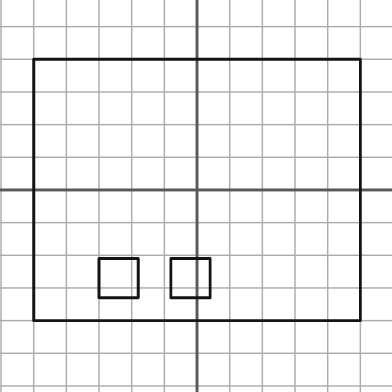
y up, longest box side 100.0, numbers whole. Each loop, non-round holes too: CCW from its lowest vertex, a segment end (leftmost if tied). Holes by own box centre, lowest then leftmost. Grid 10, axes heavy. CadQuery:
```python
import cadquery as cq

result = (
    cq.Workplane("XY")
    .moveTo(-50.0, -40.0)
    .lineTo(50.0, -40.0)
    .lineTo(50.0, 40.0)
    .lineTo(-50.0, 40.0)
    .close()
    .moveTo(-30.0, -33.0)
    .lineTo(-18.0, -33.0)
    .lineTo(-18.0, -21.0)
    .lineTo(-30.0, -21.0)
    .close()
    .moveTo(-8.0, -33.0)
    .lineTo(4.0, -33.0)
    .lineTo(4.0, -21.0)
    .lineTo(-8.0, -21.0)
    .close()
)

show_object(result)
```